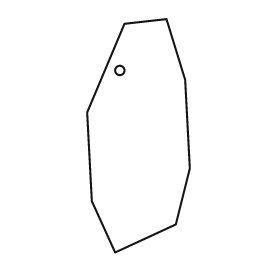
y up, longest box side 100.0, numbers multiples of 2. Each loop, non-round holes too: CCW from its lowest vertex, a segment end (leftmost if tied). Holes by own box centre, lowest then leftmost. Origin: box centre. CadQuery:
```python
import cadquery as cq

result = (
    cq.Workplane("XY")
    .moveTo(-10.0, -50.0)
    .lineTo(16.0, -38.0)
    .lineTo(22.0, -14.0)
    .lineTo(20.0, 24.0)
    .lineTo(12.0, 50.0)
    .lineTo(-6.0, 48.0)
    .lineTo(-22.0, 10.0)
    .lineTo(-20.0, -28.0)
    .close()
    .moveTo(-8.0, 28.0)
    .circle(2.0)
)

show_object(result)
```